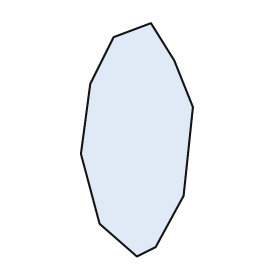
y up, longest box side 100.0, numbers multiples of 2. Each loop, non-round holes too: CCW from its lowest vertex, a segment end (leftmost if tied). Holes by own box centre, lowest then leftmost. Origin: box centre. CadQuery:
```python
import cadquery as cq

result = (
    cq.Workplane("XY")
    .moveTo(0.0, -50.0)
    .lineTo(8.0, -46.0)
    .lineTo(20.0, -24.0)
    .lineTo(24.0, 14.0)
    .lineTo(16.0, 34.0)
    .lineTo(6.0, 50.0)
    .lineTo(-10.0, 44.0)
    .lineTo(-20.0, 24.0)
    .lineTo(-24.0, -6.0)
    .lineTo(-16.0, -36.0)
    .close()
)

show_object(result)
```